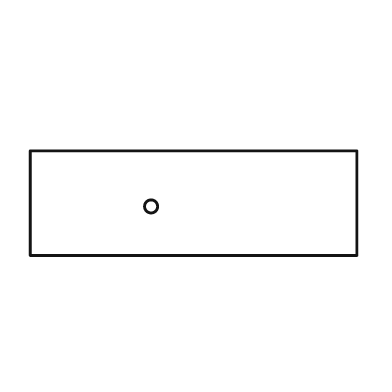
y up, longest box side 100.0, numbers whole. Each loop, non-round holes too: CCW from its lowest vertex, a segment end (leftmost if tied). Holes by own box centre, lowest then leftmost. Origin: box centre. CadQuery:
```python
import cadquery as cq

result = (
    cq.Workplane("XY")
    .moveTo(-50.0, -16.0)
    .lineTo(50.0, -16.0)
    .lineTo(50.0, 16.0)
    .lineTo(-50.0, 16.0)
    .close()
    .moveTo(-13.0, -1.0)
    .circle(2.0)
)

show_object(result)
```